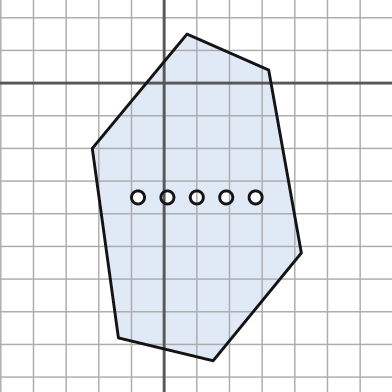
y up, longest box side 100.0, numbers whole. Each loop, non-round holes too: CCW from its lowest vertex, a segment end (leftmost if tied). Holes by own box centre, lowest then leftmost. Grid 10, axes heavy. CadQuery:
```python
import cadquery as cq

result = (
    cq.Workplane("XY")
    .moveTo(15.0, -85.0)
    .lineTo(42.0, -52.0)
    .lineTo(32.0, 4.0)
    .lineTo(7.0, 15.0)
    .lineTo(-22.0, -20.0)
    .lineTo(-14.0, -78.0)
    .close()
    .moveTo(-8.0, -35.0)
    .circle(2.0)
    .moveTo(1.0, -35.0)
    .circle(2.0)
    .moveTo(10.0, -35.0)
    .circle(2.0)
    .moveTo(19.0, -35.0)
    .circle(2.0)
    .moveTo(28.0, -35.0)
    .circle(2.0)
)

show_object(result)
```